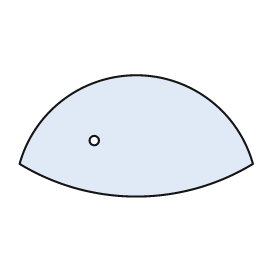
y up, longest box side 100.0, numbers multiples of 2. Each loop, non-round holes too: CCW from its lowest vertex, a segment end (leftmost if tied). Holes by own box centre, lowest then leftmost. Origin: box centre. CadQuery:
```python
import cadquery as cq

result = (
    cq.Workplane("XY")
    .moveTo(-50.0, -12.0)
    .threePointArc((0.0, -26.0), (50.0, -12.0))
    .threePointArc((0.0, 26.0), (-50.0, -12.0))
    .close()
    .moveTo(-18.0, -2.0)
    .circle(2.0)
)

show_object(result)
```